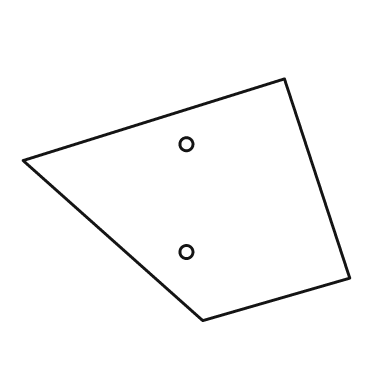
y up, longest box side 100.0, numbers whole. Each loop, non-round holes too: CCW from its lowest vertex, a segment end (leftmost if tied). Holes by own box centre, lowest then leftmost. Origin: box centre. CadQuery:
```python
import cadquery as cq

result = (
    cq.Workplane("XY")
    .moveTo(5.0, -37.0)
    .lineTo(50.0, -24.0)
    .lineTo(30.0, 37.0)
    .lineTo(-50.0, 12.0)
    .close()
    .moveTo(0.0, -16.0)
    .circle(2.0)
    .moveTo(0.0, 17.0)
    .circle(2.0)
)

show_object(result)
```